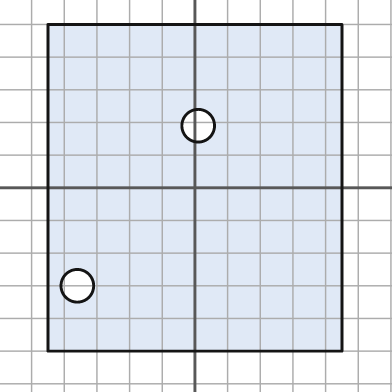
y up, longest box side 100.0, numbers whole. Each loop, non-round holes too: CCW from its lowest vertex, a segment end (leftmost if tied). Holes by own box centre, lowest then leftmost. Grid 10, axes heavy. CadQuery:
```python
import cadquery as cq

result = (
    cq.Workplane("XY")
    .moveTo(-45.0, -50.0)
    .lineTo(45.0, -50.0)
    .lineTo(45.0, 50.0)
    .lineTo(-45.0, 50.0)
    .close()
    .moveTo(-36.0, -30.0)
    .circle(5.0)
    .moveTo(1.0, 19.0)
    .circle(5.0)
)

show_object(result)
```